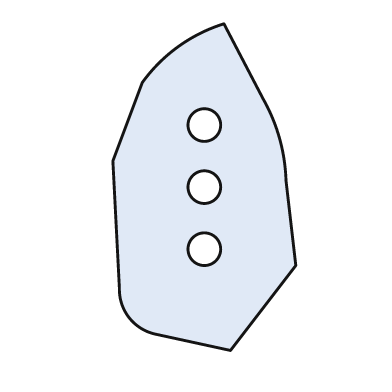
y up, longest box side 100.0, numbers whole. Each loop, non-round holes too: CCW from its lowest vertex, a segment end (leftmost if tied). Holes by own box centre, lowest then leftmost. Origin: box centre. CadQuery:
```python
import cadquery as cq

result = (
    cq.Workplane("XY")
    .moveTo(8.0, -50.0)
    .lineTo(28.0, -24.0)
    .lineTo(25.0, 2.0)
    .threePointArc((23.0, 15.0), (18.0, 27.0))
    .lineTo(6.0, 50.0)
    .threePointArc((-8.0, 43.0), (-19.0, 32.0))
    .lineTo(-28.0, 8.0)
    .lineTo(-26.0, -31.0)
    .threePointArc((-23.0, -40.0), (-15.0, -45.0))
    .close()
    .moveTo(0.0, -19.0)
    .circle(5.0)
    .moveTo(0.0, 0.0)
    .circle(5.0)
    .moveTo(0.0, 19.0)
    .circle(5.0)
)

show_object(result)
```